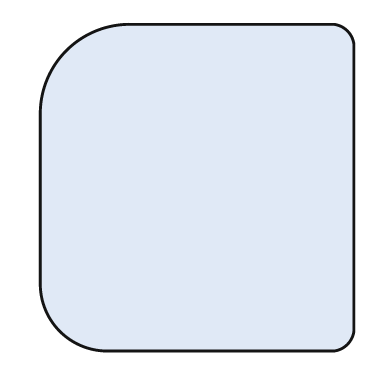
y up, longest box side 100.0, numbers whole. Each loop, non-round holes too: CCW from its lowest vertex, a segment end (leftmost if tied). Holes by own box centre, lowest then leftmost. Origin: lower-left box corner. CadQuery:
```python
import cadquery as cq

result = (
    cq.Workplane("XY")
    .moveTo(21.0, 0.0)
    .lineTo(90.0, 0.0)
    .threePointArc((94.0, 2.0), (96.0, 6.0))
    .lineTo(96.0, 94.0)
    .threePointArc((94.0, 98.0), (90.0, 100.0))
    .lineTo(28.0, 100.0)
    .threePointArc((8.0, 92.0), (0.0, 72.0))
    .lineTo(0.0, 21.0)
    .threePointArc((6.0, 6.0), (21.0, 0.0))
    .close()
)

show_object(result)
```